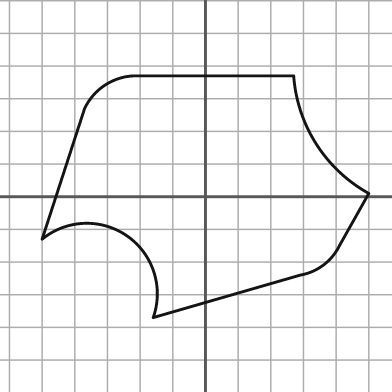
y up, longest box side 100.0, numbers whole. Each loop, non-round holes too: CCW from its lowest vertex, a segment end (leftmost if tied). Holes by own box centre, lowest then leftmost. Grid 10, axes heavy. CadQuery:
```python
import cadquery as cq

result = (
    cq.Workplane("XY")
    .moveTo(-16.0, -37.0)
    .lineTo(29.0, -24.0)
    .threePointArc((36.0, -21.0), (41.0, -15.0))
    .lineTo(50.0, 1.0)
    .threePointArc((34.0, 16.0), (27.0, 37.0))
    .lineTo(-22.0, 37.0)
    .threePointArc((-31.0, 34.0), (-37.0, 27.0))
    .lineTo(-50.0, -13.0)
    .threePointArc((-24.0, -12.0), (-16.0, -37.0))
    .close()
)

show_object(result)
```